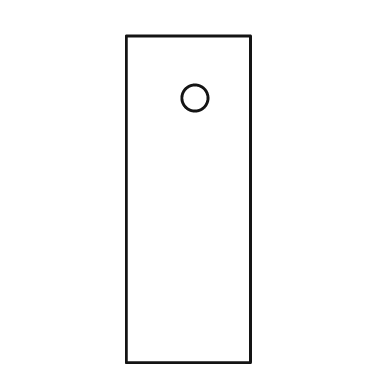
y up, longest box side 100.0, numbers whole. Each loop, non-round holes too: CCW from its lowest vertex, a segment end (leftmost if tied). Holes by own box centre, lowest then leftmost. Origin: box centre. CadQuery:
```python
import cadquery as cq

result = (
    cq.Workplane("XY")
    .moveTo(-19.0, -50.0)
    .lineTo(19.0, -50.0)
    .lineTo(19.0, 50.0)
    .lineTo(-19.0, 50.0)
    .close()
    .moveTo(2.0, 31.0)
    .circle(4.0)
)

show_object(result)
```